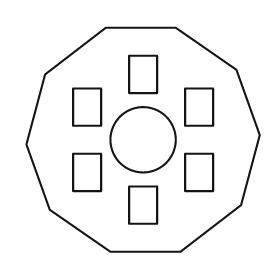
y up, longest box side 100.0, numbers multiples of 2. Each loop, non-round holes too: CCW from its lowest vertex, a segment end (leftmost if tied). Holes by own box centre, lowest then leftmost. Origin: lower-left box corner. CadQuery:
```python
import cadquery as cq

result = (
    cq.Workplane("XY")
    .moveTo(36.0, 0.0)
    .lineTo(66.0, 0.0)
    .lineTo(92.0, 20.0)
    .lineTo(100.0, 50.0)
    .lineTo(90.0, 78.0)
    .lineTo(64.0, 96.0)
    .lineTo(34.0, 96.0)
    .lineTo(8.0, 76.0)
    .lineTo(0.0, 46.0)
    .lineTo(10.0, 18.0)
    .close()
    .moveTo(44.0, 12.0)
    .lineTo(56.0, 12.0)
    .lineTo(56.0, 28.0)
    .lineTo(44.0, 28.0)
    .close()
    .moveTo(20.0, 26.0)
    .lineTo(32.0, 26.0)
    .lineTo(32.0, 42.0)
    .lineTo(20.0, 42.0)
    .close()
    .moveTo(68.0, 26.0)
    .lineTo(80.0, 26.0)
    .lineTo(80.0, 42.0)
    .lineTo(68.0, 42.0)
    .close()
    .moveTo(50.0, 48.0)
    .circle(14.0)
    .moveTo(20.0, 54.0)
    .lineTo(32.0, 54.0)
    .lineTo(32.0, 70.0)
    .lineTo(20.0, 70.0)
    .close()
    .moveTo(68.0, 54.0)
    .lineTo(80.0, 54.0)
    .lineTo(80.0, 70.0)
    .lineTo(68.0, 70.0)
    .close()
    .moveTo(44.0, 68.0)
    .lineTo(56.0, 68.0)
    .lineTo(56.0, 84.0)
    .lineTo(44.0, 84.0)
    .close()
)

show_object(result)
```